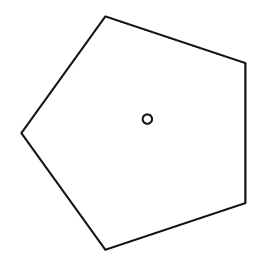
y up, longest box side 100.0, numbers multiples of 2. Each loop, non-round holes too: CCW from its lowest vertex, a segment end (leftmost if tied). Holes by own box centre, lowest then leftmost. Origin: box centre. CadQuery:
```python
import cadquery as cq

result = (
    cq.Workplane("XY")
    .moveTo(-12.0, -50.0)
    .lineTo(48.0, -30.0)
    .lineTo(48.0, 30.0)
    .lineTo(-12.0, 50.0)
    .lineTo(-48.0, 0.0)
    .close()
    .moveTo(6.0, 6.0)
    .circle(2.0)
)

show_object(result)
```